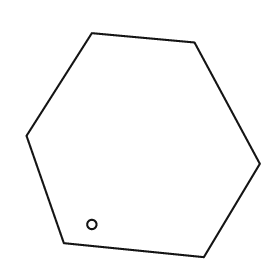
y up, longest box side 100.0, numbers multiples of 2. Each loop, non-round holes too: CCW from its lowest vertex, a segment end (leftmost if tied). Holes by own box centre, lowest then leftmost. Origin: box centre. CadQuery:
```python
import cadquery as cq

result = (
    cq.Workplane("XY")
    .moveTo(26.0, -48.0)
    .lineTo(50.0, -8.0)
    .lineTo(22.0, 44.0)
    .lineTo(-22.0, 48.0)
    .lineTo(-50.0, 4.0)
    .lineTo(-34.0, -42.0)
    .close()
    .moveTo(-22.0, -34.0)
    .circle(2.0)
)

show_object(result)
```